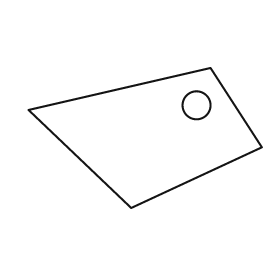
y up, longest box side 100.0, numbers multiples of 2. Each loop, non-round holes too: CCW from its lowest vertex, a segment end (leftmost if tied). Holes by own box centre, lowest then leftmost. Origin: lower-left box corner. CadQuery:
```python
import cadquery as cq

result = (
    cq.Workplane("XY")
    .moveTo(44.0, 0.0)
    .lineTo(100.0, 26.0)
    .lineTo(78.0, 60.0)
    .lineTo(0.0, 42.0)
    .close()
    .moveTo(72.0, 44.0)
    .circle(6.0)
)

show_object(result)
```